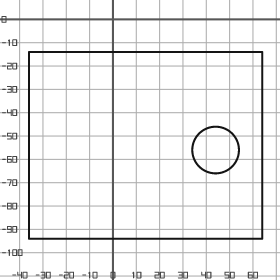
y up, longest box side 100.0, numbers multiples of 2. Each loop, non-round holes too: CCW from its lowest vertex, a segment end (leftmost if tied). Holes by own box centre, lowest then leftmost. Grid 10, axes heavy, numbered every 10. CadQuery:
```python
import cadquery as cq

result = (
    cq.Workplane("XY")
    .moveTo(-36.0, -94.0)
    .lineTo(64.0, -94.0)
    .lineTo(64.0, -14.0)
    .lineTo(-36.0, -14.0)
    .close()
    .moveTo(44.0, -56.0)
    .circle(10.0)
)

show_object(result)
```